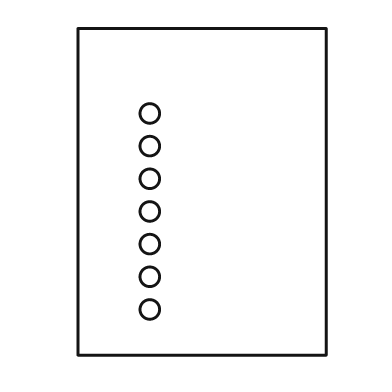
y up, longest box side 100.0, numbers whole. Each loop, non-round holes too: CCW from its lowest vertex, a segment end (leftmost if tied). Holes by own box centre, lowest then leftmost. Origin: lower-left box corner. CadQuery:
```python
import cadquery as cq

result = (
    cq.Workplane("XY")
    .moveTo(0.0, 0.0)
    .lineTo(76.0, 0.0)
    .lineTo(76.0, 100.0)
    .lineTo(0.0, 100.0)
    .close()
    .moveTo(22.0, 14.0)
    .circle(3.0)
    .moveTo(22.0, 24.0)
    .circle(3.0)
    .moveTo(22.0, 34.0)
    .circle(3.0)
    .moveTo(22.0, 44.0)
    .circle(3.0)
    .moveTo(22.0, 54.0)
    .circle(3.0)
    .moveTo(22.0, 64.0)
    .circle(3.0)
    .moveTo(22.0, 74.0)
    .circle(3.0)
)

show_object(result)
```